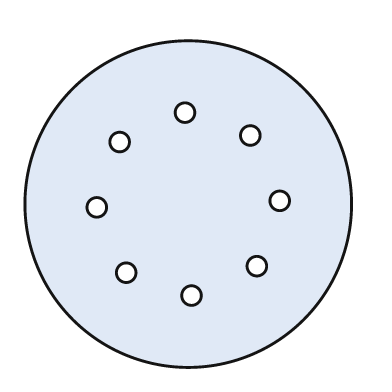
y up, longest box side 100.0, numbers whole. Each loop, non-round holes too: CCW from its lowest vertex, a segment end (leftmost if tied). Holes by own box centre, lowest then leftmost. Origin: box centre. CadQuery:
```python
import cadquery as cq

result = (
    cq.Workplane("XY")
    .moveTo(0.0, 0.0)
    .circle(50.0)
    .moveTo(1.0, -28.0)
    .circle(3.0)
    .moveTo(-19.0, -21.0)
    .circle(3.0)
    .moveTo(21.0, -19.0)
    .circle(3.0)
    .moveTo(-28.0, -1.0)
    .circle(3.0)
    .moveTo(28.0, 1.0)
    .circle(3.0)
    .moveTo(-21.0, 19.0)
    .circle(3.0)
    .moveTo(19.0, 21.0)
    .circle(3.0)
    .moveTo(-1.0, 28.0)
    .circle(3.0)
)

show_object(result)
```